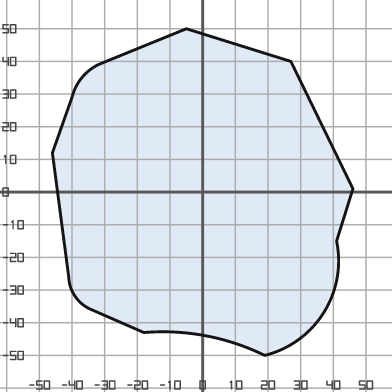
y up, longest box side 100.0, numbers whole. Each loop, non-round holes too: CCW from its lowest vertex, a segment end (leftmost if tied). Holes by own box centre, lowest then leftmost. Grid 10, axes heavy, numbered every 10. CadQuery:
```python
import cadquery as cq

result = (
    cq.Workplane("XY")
    .moveTo(19.0, -50.0)
    .threePointArc((37.0, -37.0), (41.0, -15.0))
    .lineTo(46.0, 1.0)
    .lineTo(27.0, 40.0)
    .lineTo(-5.0, 50.0)
    .lineTo(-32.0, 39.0)
    .threePointArc((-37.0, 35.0), (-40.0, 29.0))
    .lineTo(-46.0, 12.0)
    .lineTo(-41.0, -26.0)
    .threePointArc((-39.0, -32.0), (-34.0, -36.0))
    .lineTo(-18.0, -43.0)
    .threePointArc((1.0, -44.0), (19.0, -50.0))
    .close()
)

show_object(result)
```